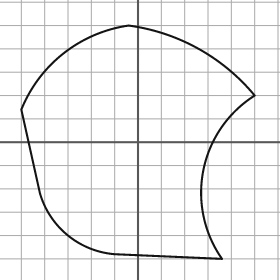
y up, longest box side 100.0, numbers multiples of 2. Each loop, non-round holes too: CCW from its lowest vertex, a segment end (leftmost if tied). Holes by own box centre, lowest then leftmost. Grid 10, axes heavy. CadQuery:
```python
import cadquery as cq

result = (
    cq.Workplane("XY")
    .moveTo(36.0, -50.0)
    .threePointArc((28.0, -12.0), (50.0, 20.0))
    .threePointArc((26.0, 40.0), (-4.0, 50.0))
    .threePointArc((-32.0, 38.0), (-50.0, 14.0))
    .lineTo(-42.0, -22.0)
    .threePointArc((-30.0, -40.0), (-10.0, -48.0))
    .close()
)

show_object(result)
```